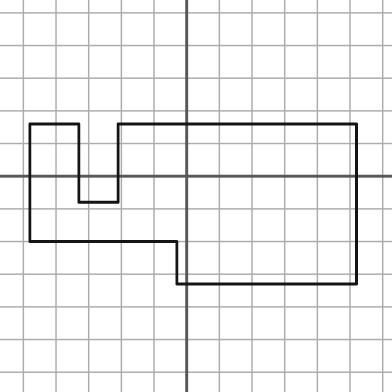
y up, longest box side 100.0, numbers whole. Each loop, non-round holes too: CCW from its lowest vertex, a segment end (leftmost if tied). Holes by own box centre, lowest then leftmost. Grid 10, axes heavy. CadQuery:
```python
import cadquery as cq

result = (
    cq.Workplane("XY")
    .moveTo(-3.0, -33.0)
    .lineTo(52.0, -33.0)
    .lineTo(52.0, 16.0)
    .lineTo(-21.0, 16.0)
    .lineTo(-21.0, -8.0)
    .lineTo(-33.0, -8.0)
    .lineTo(-33.0, 16.0)
    .lineTo(-48.0, 16.0)
    .lineTo(-48.0, -20.0)
    .lineTo(-3.0, -20.0)
    .close()
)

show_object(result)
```